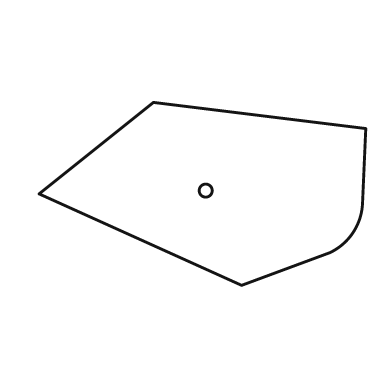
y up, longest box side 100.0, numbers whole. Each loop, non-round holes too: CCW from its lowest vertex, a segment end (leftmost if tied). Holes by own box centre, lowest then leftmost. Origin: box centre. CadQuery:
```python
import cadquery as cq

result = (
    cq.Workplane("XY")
    .moveTo(12.0, -28.0)
    .lineTo(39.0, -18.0)
    .threePointArc((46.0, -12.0), (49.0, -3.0))
    .lineTo(50.0, 20.0)
    .lineTo(-15.0, 28.0)
    .lineTo(-50.0, 0.0)
    .close()
    .moveTo(1.0, 1.0)
    .circle(2.0)
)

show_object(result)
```